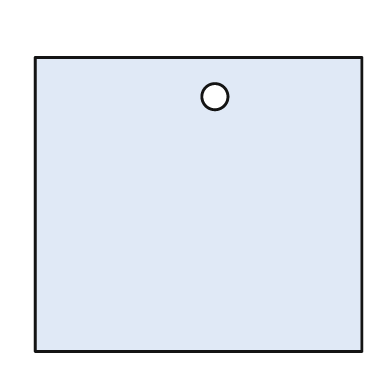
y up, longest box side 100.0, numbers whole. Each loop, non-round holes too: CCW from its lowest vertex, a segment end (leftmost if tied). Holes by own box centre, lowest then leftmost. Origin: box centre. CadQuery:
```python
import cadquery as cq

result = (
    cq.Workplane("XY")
    .moveTo(-50.0, -45.0)
    .lineTo(50.0, -45.0)
    .lineTo(50.0, 45.0)
    .lineTo(-50.0, 45.0)
    .close()
    .moveTo(5.0, 33.0)
    .circle(4.0)
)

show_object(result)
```